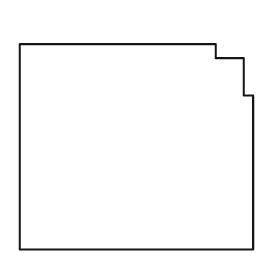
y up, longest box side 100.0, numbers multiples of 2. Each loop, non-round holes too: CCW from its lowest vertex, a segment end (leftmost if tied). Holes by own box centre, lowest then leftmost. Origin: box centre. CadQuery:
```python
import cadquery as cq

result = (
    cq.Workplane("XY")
    .moveTo(-50.0, -44.0)
    .lineTo(50.0, -44.0)
    .lineTo(50.0, 22.0)
    .lineTo(46.0, 22.0)
    .lineTo(46.0, 38.0)
    .lineTo(34.0, 38.0)
    .lineTo(34.0, 44.0)
    .lineTo(-50.0, 44.0)
    .close()
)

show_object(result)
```